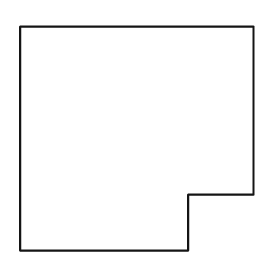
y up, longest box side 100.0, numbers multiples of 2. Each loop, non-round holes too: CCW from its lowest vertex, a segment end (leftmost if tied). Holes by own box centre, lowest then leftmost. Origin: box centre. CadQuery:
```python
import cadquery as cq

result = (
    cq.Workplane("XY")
    .moveTo(-50.0, -48.0)
    .lineTo(22.0, -48.0)
    .lineTo(22.0, -24.0)
    .lineTo(50.0, -24.0)
    .lineTo(50.0, 48.0)
    .lineTo(-50.0, 48.0)
    .close()
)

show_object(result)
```